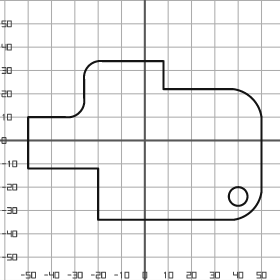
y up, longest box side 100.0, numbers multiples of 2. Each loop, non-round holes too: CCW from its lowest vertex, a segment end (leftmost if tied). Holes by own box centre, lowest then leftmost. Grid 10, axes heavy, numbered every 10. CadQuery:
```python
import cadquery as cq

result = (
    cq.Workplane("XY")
    .moveTo(-20.0, -34.0)
    .lineTo(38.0, -34.0)
    .threePointArc((46.0, -30.0), (50.0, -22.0))
    .lineTo(50.0, 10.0)
    .threePointArc((46.0, 18.0), (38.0, 22.0))
    .lineTo(8.0, 22.0)
    .lineTo(8.0, 34.0)
    .lineTo(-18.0, 34.0)
    .threePointArc((-24.0, 32.0), (-26.0, 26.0))
    .lineTo(-26.0, 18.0)
    .threePointArc((-28.0, 12.0), (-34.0, 10.0))
    .lineTo(-50.0, 10.0)
    .lineTo(-50.0, -12.0)
    .lineTo(-20.0, -12.0)
    .close()
    .moveTo(40.0, -24.0)
    .circle(4.0)
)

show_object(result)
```